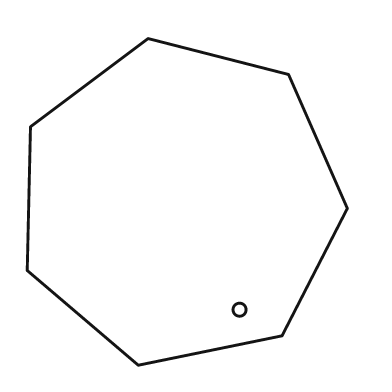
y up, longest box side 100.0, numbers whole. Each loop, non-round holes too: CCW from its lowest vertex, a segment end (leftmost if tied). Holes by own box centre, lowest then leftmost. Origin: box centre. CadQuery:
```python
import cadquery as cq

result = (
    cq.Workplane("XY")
    .moveTo(-15.0, -50.0)
    .lineTo(29.0, -41.0)
    .lineTo(49.0, -2.0)
    .lineTo(31.0, 39.0)
    .lineTo(-12.0, 50.0)
    .lineTo(-48.0, 23.0)
    .lineTo(-49.0, -21.0)
    .close()
    .moveTo(16.0, -33.0)
    .circle(2.0)
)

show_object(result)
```